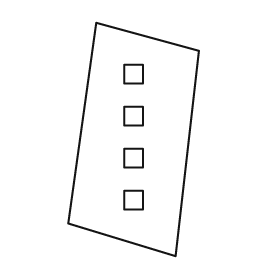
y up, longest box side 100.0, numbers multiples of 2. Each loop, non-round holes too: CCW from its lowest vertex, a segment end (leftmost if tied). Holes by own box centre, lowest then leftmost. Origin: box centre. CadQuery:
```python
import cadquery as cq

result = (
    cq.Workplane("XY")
    .moveTo(18.0, -50.0)
    .lineTo(28.0, 38.0)
    .lineTo(-16.0, 50.0)
    .lineTo(-28.0, -36.0)
    .close()
    .moveTo(-4.0, -30.0)
    .lineTo(4.0, -30.0)
    .lineTo(4.0, -22.0)
    .lineTo(-4.0, -22.0)
    .close()
    .moveTo(-4.0, -12.0)
    .lineTo(4.0, -12.0)
    .lineTo(4.0, -4.0)
    .lineTo(-4.0, -4.0)
    .close()
    .moveTo(-4.0, 6.0)
    .lineTo(4.0, 6.0)
    .lineTo(4.0, 14.0)
    .lineTo(-4.0, 14.0)
    .close()
    .moveTo(-4.0, 24.0)
    .lineTo(4.0, 24.0)
    .lineTo(4.0, 32.0)
    .lineTo(-4.0, 32.0)
    .close()
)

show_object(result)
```